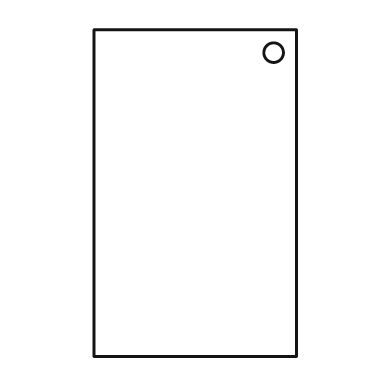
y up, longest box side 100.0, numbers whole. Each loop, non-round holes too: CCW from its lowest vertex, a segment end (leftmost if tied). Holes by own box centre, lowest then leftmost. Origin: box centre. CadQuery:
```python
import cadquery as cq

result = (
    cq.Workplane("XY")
    .moveTo(-31.0, -50.0)
    .lineTo(31.0, -50.0)
    .lineTo(31.0, 50.0)
    .lineTo(-31.0, 50.0)
    .close()
    .moveTo(24.0, 43.0)
    .circle(3.0)
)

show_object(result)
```